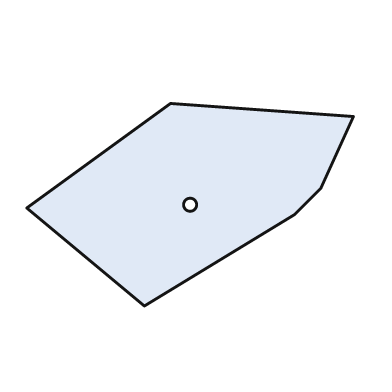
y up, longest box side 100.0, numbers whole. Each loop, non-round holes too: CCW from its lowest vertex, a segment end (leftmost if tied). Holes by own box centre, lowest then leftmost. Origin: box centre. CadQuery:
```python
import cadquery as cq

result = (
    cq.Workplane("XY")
    .moveTo(-14.0, -31.0)
    .lineTo(32.0, -3.0)
    .lineTo(40.0, 5.0)
    .lineTo(50.0, 27.0)
    .lineTo(-6.0, 31.0)
    .lineTo(-50.0, -1.0)
    .close()
    .moveTo(0.0, 0.0)
    .circle(2.0)
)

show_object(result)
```